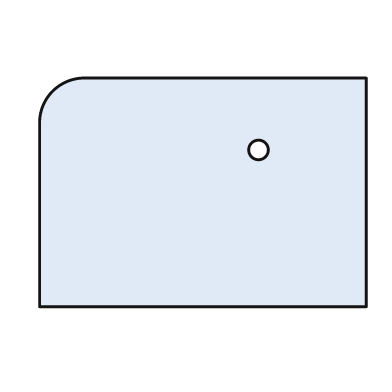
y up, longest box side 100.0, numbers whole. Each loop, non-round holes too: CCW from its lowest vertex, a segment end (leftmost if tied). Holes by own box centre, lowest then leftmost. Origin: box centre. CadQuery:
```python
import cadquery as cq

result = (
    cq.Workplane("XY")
    .moveTo(-50.0, -35.0)
    .lineTo(50.0, -35.0)
    .lineTo(50.0, 35.0)
    .lineTo(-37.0, 35.0)
    .threePointArc((-46.0, 31.0), (-50.0, 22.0))
    .close()
    .moveTo(17.0, 13.0)
    .circle(3.0)
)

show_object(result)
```